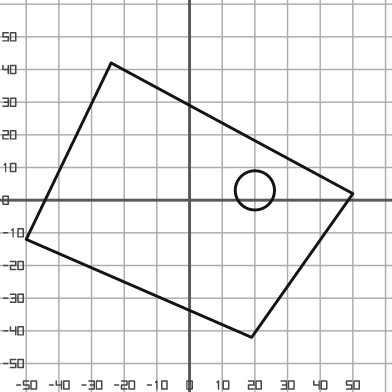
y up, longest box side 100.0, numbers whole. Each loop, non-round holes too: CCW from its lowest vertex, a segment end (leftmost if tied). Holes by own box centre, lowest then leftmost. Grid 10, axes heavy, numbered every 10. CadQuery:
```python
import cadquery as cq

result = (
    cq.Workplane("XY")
    .moveTo(19.0, -42.0)
    .lineTo(50.0, 2.0)
    .lineTo(-24.0, 42.0)
    .lineTo(-50.0, -12.0)
    .close()
    .moveTo(20.0, 3.0)
    .circle(6.0)
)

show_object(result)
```